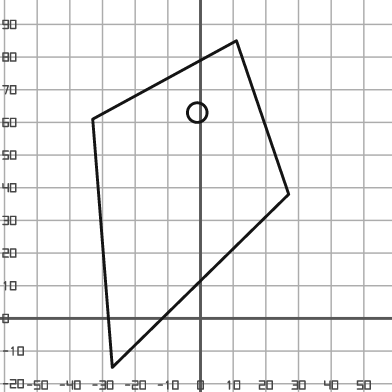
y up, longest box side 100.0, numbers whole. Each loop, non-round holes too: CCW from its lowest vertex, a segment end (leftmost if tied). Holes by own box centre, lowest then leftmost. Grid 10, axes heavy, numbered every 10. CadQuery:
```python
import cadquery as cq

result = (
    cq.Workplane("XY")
    .moveTo(-27.0, -15.0)
    .lineTo(27.0, 38.0)
    .lineTo(11.0, 85.0)
    .lineTo(-33.0, 61.0)
    .close()
    .moveTo(-1.0, 63.0)
    .circle(3.0)
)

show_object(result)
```